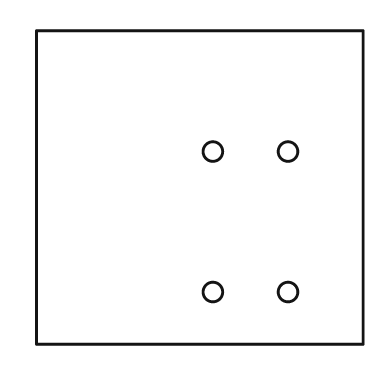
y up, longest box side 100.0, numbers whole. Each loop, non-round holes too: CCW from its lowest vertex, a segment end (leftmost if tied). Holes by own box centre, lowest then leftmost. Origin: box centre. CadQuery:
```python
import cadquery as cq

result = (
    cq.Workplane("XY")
    .moveTo(-50.0, -48.0)
    .lineTo(50.0, -48.0)
    .lineTo(50.0, 48.0)
    .lineTo(-50.0, 48.0)
    .close()
    .moveTo(4.0, -32.0)
    .circle(3.0)
    .moveTo(27.0, -32.0)
    .circle(3.0)
    .moveTo(4.0, 11.0)
    .circle(3.0)
    .moveTo(27.0, 11.0)
    .circle(3.0)
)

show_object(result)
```